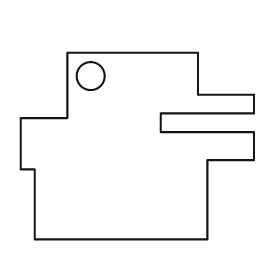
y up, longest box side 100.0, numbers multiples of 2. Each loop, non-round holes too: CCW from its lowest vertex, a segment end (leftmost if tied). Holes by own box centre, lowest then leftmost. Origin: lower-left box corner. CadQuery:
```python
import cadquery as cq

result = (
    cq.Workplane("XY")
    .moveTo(6.0, 0.0)
    .lineTo(80.0, 0.0)
    .lineTo(80.0, 34.0)
    .lineTo(100.0, 34.0)
    .lineTo(100.0, 46.0)
    .lineTo(60.0, 46.0)
    .lineTo(60.0, 54.0)
    .lineTo(100.0, 54.0)
    .lineTo(100.0, 62.0)
    .lineTo(76.0, 62.0)
    .lineTo(76.0, 80.0)
    .lineTo(20.0, 80.0)
    .lineTo(20.0, 52.0)
    .lineTo(0.0, 52.0)
    .lineTo(0.0, 30.0)
    .lineTo(6.0, 30.0)
    .close()
    .moveTo(30.0, 70.0)
    .circle(6.0)
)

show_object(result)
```